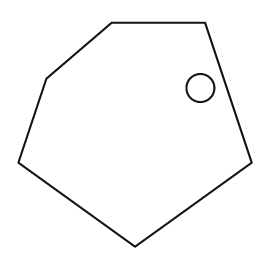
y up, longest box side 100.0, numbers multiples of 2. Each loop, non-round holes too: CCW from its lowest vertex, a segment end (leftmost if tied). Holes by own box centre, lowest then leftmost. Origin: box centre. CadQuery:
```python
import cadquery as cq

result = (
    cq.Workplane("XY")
    .moveTo(0.0, -48.0)
    .lineTo(50.0, -12.0)
    .lineTo(30.0, 48.0)
    .lineTo(-10.0, 48.0)
    .lineTo(-38.0, 24.0)
    .lineTo(-50.0, -12.0)
    .close()
    .moveTo(28.0, 20.0)
    .circle(6.0)
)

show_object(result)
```